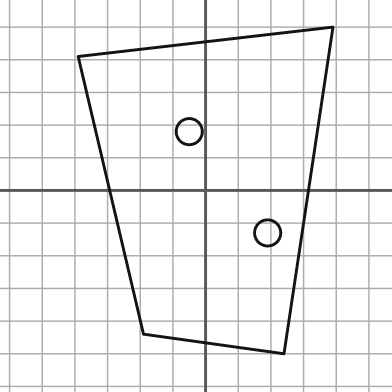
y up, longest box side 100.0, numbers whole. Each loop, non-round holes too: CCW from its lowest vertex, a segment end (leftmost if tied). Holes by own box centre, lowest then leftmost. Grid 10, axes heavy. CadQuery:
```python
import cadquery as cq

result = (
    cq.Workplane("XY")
    .moveTo(24.0, -50.0)
    .lineTo(39.0, 50.0)
    .lineTo(-39.0, 41.0)
    .lineTo(-19.0, -44.0)
    .close()
    .moveTo(19.0, -13.0)
    .circle(4.0)
    .moveTo(-5.0, 18.0)
    .circle(4.0)
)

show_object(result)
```